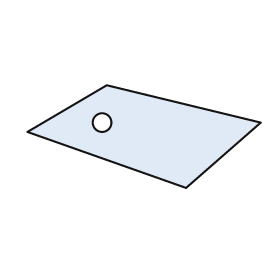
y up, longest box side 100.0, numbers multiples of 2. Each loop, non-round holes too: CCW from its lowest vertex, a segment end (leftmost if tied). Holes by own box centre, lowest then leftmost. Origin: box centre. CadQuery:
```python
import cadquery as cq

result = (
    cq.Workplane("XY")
    .moveTo(18.0, -22.0)
    .lineTo(50.0, 6.0)
    .lineTo(-16.0, 22.0)
    .lineTo(-50.0, 2.0)
    .close()
    .moveTo(-18.0, 6.0)
    .circle(4.0)
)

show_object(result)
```